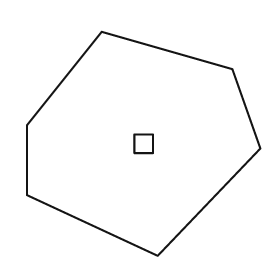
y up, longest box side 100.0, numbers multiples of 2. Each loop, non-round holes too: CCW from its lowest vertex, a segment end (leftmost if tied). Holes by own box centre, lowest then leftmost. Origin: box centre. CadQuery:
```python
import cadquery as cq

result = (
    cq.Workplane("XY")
    .moveTo(6.0, -48.0)
    .lineTo(50.0, -2.0)
    .lineTo(38.0, 32.0)
    .lineTo(-18.0, 48.0)
    .lineTo(-50.0, 8.0)
    .lineTo(-50.0, -22.0)
    .close()
    .moveTo(-4.0, -4.0)
    .lineTo(4.0, -4.0)
    .lineTo(4.0, 4.0)
    .lineTo(-4.0, 4.0)
    .close()
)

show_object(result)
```